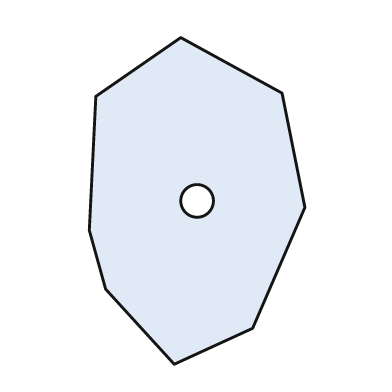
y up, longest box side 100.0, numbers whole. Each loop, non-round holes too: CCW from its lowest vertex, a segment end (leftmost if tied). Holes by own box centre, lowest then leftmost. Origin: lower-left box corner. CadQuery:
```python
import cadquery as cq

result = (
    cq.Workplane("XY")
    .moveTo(26.0, 0.0)
    .lineTo(50.0, 11.0)
    .lineTo(66.0, 48.0)
    .lineTo(59.0, 83.0)
    .lineTo(28.0, 100.0)
    .lineTo(2.0, 82.0)
    .lineTo(0.0, 41.0)
    .lineTo(5.0, 23.0)
    .close()
    .moveTo(33.0, 50.0)
    .circle(5.0)
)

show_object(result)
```